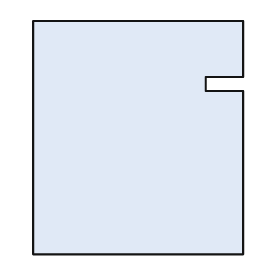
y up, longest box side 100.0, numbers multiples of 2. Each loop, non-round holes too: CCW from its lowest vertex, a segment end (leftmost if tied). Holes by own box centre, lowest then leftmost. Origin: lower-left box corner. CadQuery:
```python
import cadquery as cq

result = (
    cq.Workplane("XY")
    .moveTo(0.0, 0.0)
    .lineTo(90.0, 0.0)
    .lineTo(90.0, 70.0)
    .lineTo(74.0, 70.0)
    .lineTo(74.0, 76.0)
    .lineTo(90.0, 76.0)
    .lineTo(90.0, 100.0)
    .lineTo(0.0, 100.0)
    .close()
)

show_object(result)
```